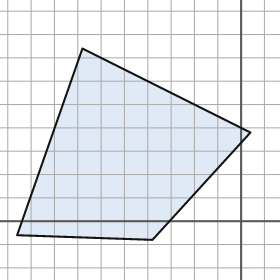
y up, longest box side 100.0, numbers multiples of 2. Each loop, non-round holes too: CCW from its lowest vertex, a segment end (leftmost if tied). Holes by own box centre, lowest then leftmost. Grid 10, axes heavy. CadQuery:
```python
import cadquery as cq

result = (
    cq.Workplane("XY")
    .moveTo(-38.0, -8.0)
    .lineTo(4.0, 38.0)
    .lineTo(-68.0, 74.0)
    .lineTo(-96.0, -6.0)
    .close()
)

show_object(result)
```